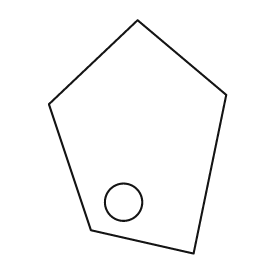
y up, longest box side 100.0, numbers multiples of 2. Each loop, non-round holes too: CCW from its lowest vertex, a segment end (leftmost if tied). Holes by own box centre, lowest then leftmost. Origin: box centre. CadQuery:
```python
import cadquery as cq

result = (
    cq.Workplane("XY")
    .moveTo(24.0, -50.0)
    .lineTo(38.0, 18.0)
    .lineTo(0.0, 50.0)
    .lineTo(-38.0, 14.0)
    .lineTo(-20.0, -40.0)
    .close()
    .moveTo(-6.0, -28.0)
    .circle(8.0)
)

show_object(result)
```